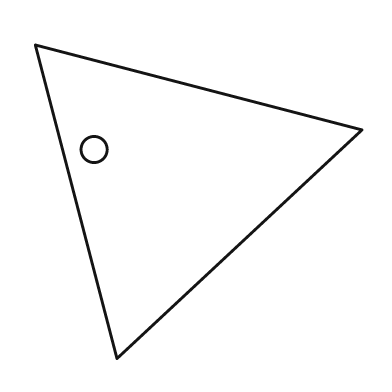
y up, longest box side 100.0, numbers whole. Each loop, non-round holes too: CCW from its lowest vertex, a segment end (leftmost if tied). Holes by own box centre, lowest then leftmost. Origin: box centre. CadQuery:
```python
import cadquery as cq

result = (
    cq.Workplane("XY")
    .moveTo(-25.0, -48.0)
    .lineTo(50.0, 22.0)
    .lineTo(-50.0, 48.0)
    .close()
    .moveTo(-32.0, 16.0)
    .circle(4.0)
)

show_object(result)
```